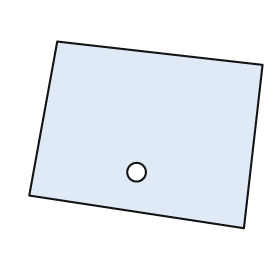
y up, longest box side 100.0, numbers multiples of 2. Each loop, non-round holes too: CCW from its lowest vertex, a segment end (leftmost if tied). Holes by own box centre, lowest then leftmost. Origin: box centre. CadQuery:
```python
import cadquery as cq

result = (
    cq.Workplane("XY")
    .moveTo(42.0, -40.0)
    .lineTo(50.0, 30.0)
    .lineTo(-38.0, 40.0)
    .lineTo(-50.0, -26.0)
    .close()
    .moveTo(-4.0, -16.0)
    .circle(4.0)
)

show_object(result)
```